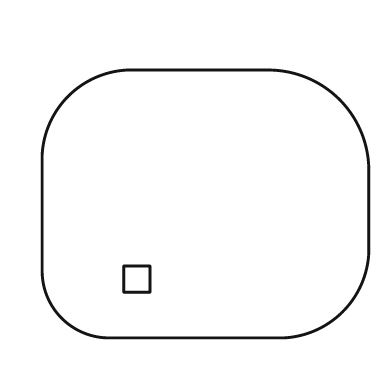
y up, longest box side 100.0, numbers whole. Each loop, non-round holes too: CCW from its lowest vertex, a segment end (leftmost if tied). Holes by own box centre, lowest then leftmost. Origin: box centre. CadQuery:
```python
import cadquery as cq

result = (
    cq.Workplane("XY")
    .moveTo(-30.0, -41.0)
    .lineTo(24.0, -41.0)
    .threePointArc((42.0, -33.0), (50.0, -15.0))
    .lineTo(50.0, 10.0)
    .threePointArc((41.0, 32.0), (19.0, 41.0))
    .lineTo(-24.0, 41.0)
    .threePointArc((-42.0, 33.0), (-50.0, 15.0))
    .lineTo(-50.0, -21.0)
    .threePointArc((-44.0, -35.0), (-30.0, -41.0))
    .close()
    .moveTo(-25.0, -27.0)
    .lineTo(-17.0, -27.0)
    .lineTo(-17.0, -19.0)
    .lineTo(-25.0, -19.0)
    .close()
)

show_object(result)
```